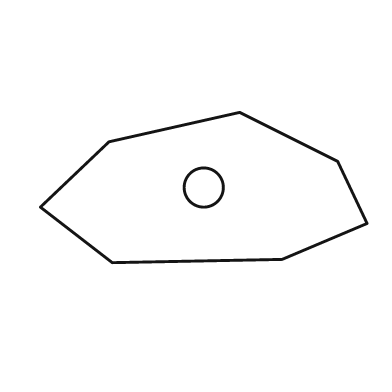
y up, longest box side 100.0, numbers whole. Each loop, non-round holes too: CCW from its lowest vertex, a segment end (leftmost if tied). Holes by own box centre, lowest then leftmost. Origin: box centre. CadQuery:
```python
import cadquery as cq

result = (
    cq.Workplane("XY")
    .moveTo(-28.0, -23.0)
    .lineTo(24.0, -22.0)
    .lineTo(50.0, -11.0)
    .lineTo(41.0, 8.0)
    .lineTo(11.0, 23.0)
    .lineTo(-29.0, 14.0)
    .lineTo(-50.0, -6.0)
    .close()
    .moveTo(0.0, 0.0)
    .circle(6.0)
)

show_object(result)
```